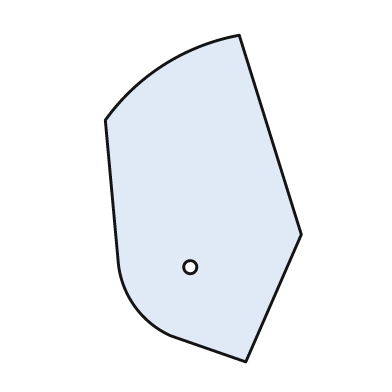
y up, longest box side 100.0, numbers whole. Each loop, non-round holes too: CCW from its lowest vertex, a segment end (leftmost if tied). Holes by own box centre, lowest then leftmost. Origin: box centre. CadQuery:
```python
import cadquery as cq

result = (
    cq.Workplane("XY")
    .moveTo(13.0, -50.0)
    .lineTo(30.0, -11.0)
    .lineTo(11.0, 50.0)
    .threePointArc((-12.0, 41.0), (-30.0, 24.0))
    .lineTo(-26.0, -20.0)
    .threePointArc((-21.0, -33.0), (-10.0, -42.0))
    .close()
    .moveTo(-4.0, -21.0)
    .circle(2.0)
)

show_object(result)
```